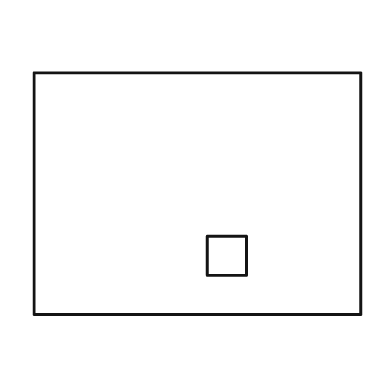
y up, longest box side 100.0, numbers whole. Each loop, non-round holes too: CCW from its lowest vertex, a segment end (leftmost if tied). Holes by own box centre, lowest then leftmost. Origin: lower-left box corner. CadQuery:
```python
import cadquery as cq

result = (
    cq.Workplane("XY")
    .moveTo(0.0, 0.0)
    .lineTo(100.0, 0.0)
    .lineTo(100.0, 74.0)
    .lineTo(0.0, 74.0)
    .close()
    .moveTo(53.0, 12.0)
    .lineTo(65.0, 12.0)
    .lineTo(65.0, 24.0)
    .lineTo(53.0, 24.0)
    .close()
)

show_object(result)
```